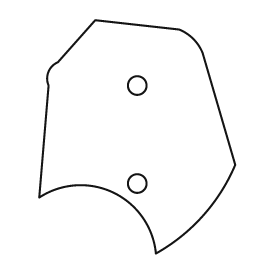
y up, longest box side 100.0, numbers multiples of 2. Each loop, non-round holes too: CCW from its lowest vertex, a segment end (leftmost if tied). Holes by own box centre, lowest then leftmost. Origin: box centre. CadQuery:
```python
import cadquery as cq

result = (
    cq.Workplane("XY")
    .moveTo(8.0, -50.0)
    .threePointArc((28.0, -34.0), (42.0, -12.0))
    .lineTo(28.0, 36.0)
    .threePointArc((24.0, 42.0), (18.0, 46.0))
    .lineTo(-18.0, 50.0)
    .lineTo(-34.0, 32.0)
    .threePointArc((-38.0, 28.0), (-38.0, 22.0))
    .lineTo(-42.0, -26.0)
    .threePointArc((-10.0, -24.0), (8.0, -50.0))
    .close()
    .moveTo(0.0, -20.0)
    .circle(4.0)
    .moveTo(0.0, 22.0)
    .circle(4.0)
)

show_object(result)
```